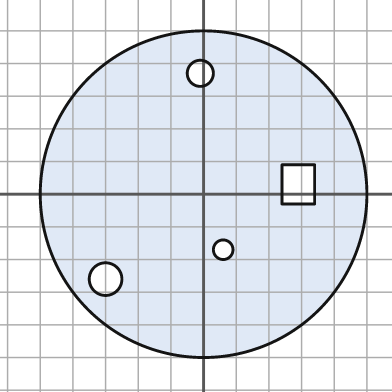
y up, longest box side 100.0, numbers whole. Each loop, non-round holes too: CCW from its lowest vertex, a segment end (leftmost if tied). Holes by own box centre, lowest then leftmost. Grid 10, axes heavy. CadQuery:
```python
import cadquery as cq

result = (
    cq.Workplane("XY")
    .moveTo(0.0, 0.0)
    .circle(50.0)
    .moveTo(-30.0, -26.0)
    .circle(5.0)
    .moveTo(6.0, -17.0)
    .circle(3.0)
    .moveTo(24.0, -3.0)
    .lineTo(34.0, -3.0)
    .lineTo(34.0, 9.0)
    .lineTo(24.0, 9.0)
    .close()
    .moveTo(-1.0, 37.0)
    .circle(4.0)
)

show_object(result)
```